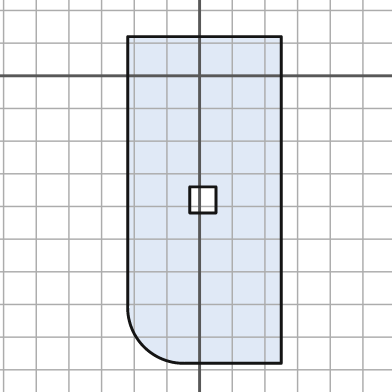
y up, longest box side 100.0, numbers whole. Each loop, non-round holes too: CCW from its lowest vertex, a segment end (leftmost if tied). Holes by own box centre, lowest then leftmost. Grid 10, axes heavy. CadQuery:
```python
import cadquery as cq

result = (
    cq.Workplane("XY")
    .moveTo(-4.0, -88.0)
    .lineTo(25.0, -88.0)
    .lineTo(25.0, 12.0)
    .lineTo(-22.0, 12.0)
    .lineTo(-22.0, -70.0)
    .threePointArc((-17.0, -83.0), (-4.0, -88.0))
    .close()
    .moveTo(-3.0, -42.0)
    .lineTo(5.0, -42.0)
    .lineTo(5.0, -34.0)
    .lineTo(-3.0, -34.0)
    .close()
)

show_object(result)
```